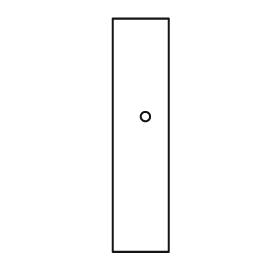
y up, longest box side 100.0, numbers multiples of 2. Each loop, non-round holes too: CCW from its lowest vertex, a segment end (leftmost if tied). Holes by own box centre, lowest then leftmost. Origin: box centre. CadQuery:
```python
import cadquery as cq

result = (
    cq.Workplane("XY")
    .moveTo(-12.0, -50.0)
    .lineTo(12.0, -50.0)
    .lineTo(12.0, 50.0)
    .lineTo(-12.0, 50.0)
    .close()
    .moveTo(2.0, 8.0)
    .circle(2.0)
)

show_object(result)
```